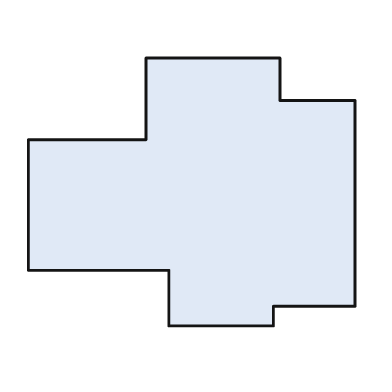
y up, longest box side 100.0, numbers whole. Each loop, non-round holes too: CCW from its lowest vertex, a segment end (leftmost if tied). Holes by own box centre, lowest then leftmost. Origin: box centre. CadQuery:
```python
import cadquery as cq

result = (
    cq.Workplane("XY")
    .moveTo(-7.0, -41.0)
    .lineTo(25.0, -41.0)
    .lineTo(25.0, -35.0)
    .lineTo(50.0, -35.0)
    .lineTo(50.0, 28.0)
    .lineTo(27.0, 28.0)
    .lineTo(27.0, 41.0)
    .lineTo(-14.0, 41.0)
    .lineTo(-14.0, 16.0)
    .lineTo(-50.0, 16.0)
    .lineTo(-50.0, -24.0)
    .lineTo(-7.0, -24.0)
    .close()
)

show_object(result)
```